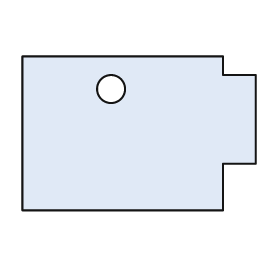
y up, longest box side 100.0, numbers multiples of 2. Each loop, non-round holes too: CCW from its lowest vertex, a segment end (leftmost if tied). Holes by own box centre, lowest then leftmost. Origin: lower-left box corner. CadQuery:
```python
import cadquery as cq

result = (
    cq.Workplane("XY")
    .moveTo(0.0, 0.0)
    .lineTo(86.0, 0.0)
    .lineTo(86.0, 20.0)
    .lineTo(100.0, 20.0)
    .lineTo(100.0, 58.0)
    .lineTo(86.0, 58.0)
    .lineTo(86.0, 66.0)
    .lineTo(0.0, 66.0)
    .close()
    .moveTo(38.0, 52.0)
    .circle(6.0)
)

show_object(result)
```